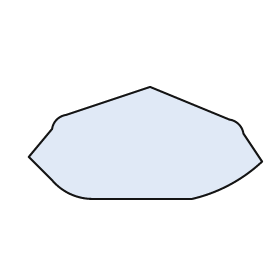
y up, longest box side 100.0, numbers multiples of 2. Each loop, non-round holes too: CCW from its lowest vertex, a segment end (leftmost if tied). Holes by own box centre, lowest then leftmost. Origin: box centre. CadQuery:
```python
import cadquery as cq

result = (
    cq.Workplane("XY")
    .moveTo(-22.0, -24.0)
    .lineTo(20.0, -24.0)
    .threePointArc((36.0, -18.0), (50.0, -8.0))
    .lineTo(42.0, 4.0)
    .threePointArc((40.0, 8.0), (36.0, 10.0))
    .lineTo(2.0, 24.0)
    .lineTo(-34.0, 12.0)
    .threePointArc((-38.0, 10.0), (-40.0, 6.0))
    .lineTo(-50.0, -6.0)
    .lineTo(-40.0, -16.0)
    .threePointArc((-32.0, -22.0), (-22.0, -24.0))
    .close()
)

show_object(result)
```